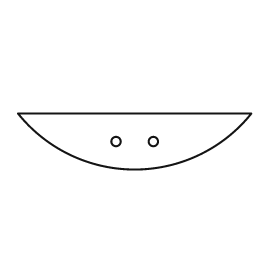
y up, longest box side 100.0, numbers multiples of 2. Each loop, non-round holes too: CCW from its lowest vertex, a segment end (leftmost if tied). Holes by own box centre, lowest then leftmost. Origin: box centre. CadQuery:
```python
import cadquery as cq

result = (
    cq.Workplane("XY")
    .moveTo(-50.0, 12.0)
    .threePointArc((0.0, -12.0), (50.0, 12.0))
    .close()
    .moveTo(-8.0, 0.0)
    .circle(2.0)
    .moveTo(8.0, 0.0)
    .circle(2.0)
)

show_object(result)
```